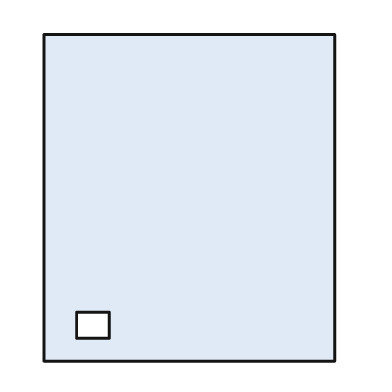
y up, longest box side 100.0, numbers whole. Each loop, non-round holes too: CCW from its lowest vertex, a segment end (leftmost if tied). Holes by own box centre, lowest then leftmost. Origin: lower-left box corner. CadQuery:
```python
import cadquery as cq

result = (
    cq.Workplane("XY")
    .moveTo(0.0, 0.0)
    .lineTo(89.0, 0.0)
    .lineTo(89.0, 100.0)
    .lineTo(0.0, 100.0)
    .close()
    .moveTo(10.0, 7.0)
    .lineTo(20.0, 7.0)
    .lineTo(20.0, 15.0)
    .lineTo(10.0, 15.0)
    .close()
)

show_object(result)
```